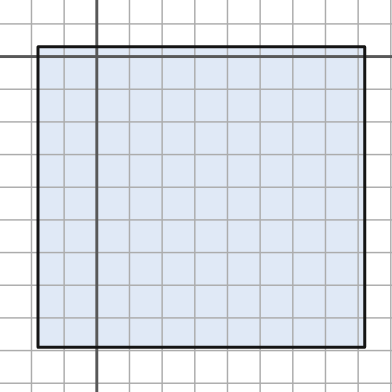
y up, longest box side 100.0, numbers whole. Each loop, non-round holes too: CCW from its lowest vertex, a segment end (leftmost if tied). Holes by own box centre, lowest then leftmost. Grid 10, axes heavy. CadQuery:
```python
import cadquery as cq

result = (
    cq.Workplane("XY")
    .moveTo(-18.0, -89.0)
    .lineTo(82.0, -89.0)
    .lineTo(82.0, 3.0)
    .lineTo(-18.0, 3.0)
    .close()
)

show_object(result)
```